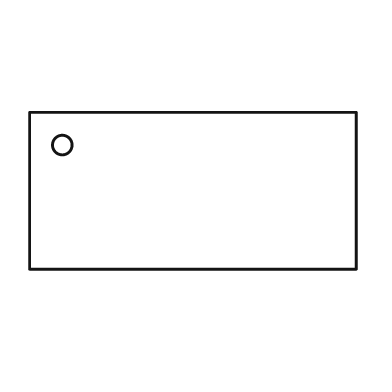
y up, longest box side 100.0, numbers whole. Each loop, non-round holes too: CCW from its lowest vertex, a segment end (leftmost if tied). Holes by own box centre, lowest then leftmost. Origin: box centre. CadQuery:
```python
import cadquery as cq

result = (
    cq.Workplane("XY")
    .moveTo(-50.0, -24.0)
    .lineTo(50.0, -24.0)
    .lineTo(50.0, 24.0)
    .lineTo(-50.0, 24.0)
    .close()
    .moveTo(-40.0, 14.0)
    .circle(3.0)
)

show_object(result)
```